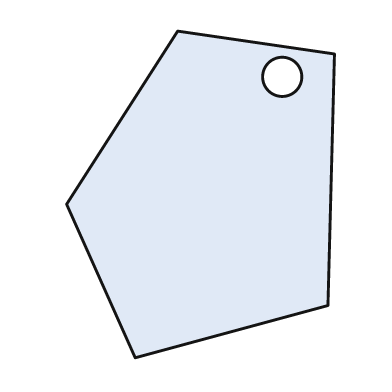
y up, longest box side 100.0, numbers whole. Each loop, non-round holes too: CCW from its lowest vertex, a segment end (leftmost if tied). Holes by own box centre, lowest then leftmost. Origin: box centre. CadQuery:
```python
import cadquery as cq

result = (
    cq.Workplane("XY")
    .moveTo(-20.0, -50.0)
    .lineTo(39.0, -34.0)
    .lineTo(41.0, 43.0)
    .lineTo(-7.0, 50.0)
    .lineTo(-41.0, -3.0)
    .close()
    .moveTo(25.0, 36.0)
    .circle(6.0)
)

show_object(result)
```